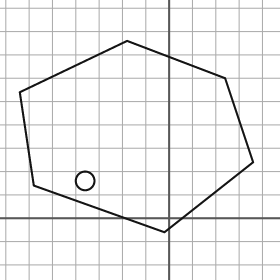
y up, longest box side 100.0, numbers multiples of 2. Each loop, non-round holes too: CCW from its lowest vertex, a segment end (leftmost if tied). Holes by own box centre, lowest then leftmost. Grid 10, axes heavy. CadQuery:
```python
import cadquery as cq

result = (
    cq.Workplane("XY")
    .moveTo(-2.0, -6.0)
    .lineTo(36.0, 24.0)
    .lineTo(24.0, 60.0)
    .lineTo(-18.0, 76.0)
    .lineTo(-64.0, 54.0)
    .lineTo(-58.0, 14.0)
    .close()
    .moveTo(-36.0, 16.0)
    .circle(4.0)
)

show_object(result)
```